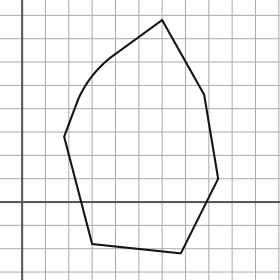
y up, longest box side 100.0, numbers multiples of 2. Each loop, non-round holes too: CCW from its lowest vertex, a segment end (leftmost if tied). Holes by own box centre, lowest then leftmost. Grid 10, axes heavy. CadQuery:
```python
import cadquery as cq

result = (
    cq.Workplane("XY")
    .moveTo(68.0, -22.0)
    .lineTo(84.0, 10.0)
    .lineTo(78.0, 46.0)
    .lineTo(60.0, 78.0)
    .lineTo(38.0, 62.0)
    .threePointArc((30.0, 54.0), (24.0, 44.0))
    .lineTo(18.0, 28.0)
    .lineTo(30.0, -18.0)
    .close()
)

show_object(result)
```